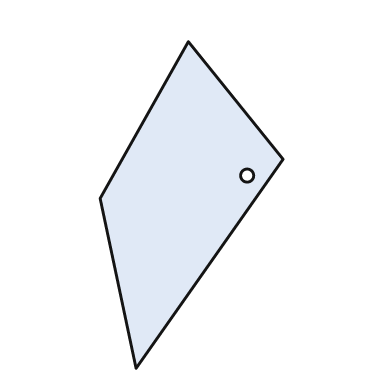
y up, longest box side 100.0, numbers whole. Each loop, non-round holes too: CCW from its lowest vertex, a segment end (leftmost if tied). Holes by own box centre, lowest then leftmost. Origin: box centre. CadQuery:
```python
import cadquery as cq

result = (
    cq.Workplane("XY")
    .moveTo(-17.0, -50.0)
    .lineTo(28.0, 14.0)
    .lineTo(-1.0, 50.0)
    .lineTo(-28.0, 2.0)
    .close()
    .moveTo(17.0, 9.0)
    .circle(2.0)
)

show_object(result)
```